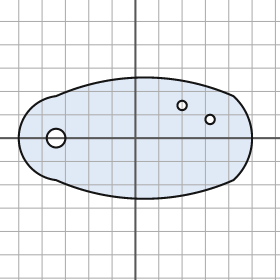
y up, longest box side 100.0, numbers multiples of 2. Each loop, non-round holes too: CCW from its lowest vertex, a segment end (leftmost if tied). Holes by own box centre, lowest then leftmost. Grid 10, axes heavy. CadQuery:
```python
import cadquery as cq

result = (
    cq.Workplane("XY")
    .moveTo(-34.0, -18.0)
    .threePointArc((4.0, -26.0), (42.0, -18.0))
    .threePointArc((50.0, 0.0), (42.0, 18.0))
    .threePointArc((4.0, 26.0), (-34.0, 18.0))
    .threePointArc((-50.0, 0.0), (-34.0, -18.0))
    .close()
    .moveTo(-34.0, 0.0)
    .circle(4.0)
    .moveTo(32.0, 8.0)
    .circle(2.0)
    .moveTo(20.0, 14.0)
    .circle(2.0)
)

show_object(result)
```